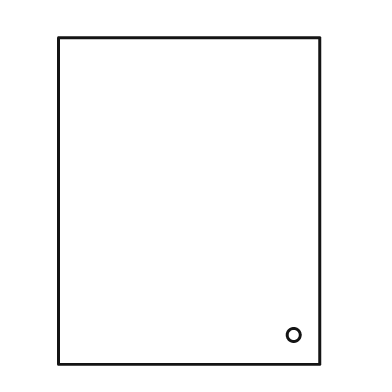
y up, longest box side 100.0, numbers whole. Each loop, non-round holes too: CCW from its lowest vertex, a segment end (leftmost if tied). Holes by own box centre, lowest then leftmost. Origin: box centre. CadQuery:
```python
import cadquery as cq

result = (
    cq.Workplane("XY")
    .moveTo(-40.0, -50.0)
    .lineTo(40.0, -50.0)
    .lineTo(40.0, 50.0)
    .lineTo(-40.0, 50.0)
    .close()
    .moveTo(32.0, -41.0)
    .circle(2.0)
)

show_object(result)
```